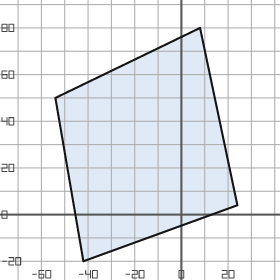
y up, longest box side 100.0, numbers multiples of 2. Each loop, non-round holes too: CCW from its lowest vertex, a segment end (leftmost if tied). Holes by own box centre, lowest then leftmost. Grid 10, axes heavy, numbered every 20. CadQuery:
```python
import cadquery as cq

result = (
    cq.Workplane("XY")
    .moveTo(-42.0, -20.0)
    .lineTo(24.0, 4.0)
    .lineTo(8.0, 80.0)
    .lineTo(-54.0, 50.0)
    .close()
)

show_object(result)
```